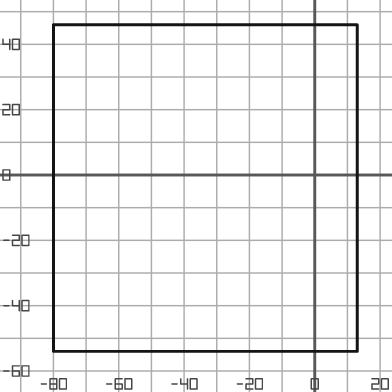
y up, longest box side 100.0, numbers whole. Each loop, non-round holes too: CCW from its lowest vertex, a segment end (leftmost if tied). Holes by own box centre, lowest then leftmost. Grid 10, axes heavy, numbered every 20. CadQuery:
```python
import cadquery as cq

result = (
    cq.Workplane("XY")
    .moveTo(-80.0, -54.0)
    .lineTo(13.0, -54.0)
    .lineTo(13.0, 46.0)
    .lineTo(-80.0, 46.0)
    .close()
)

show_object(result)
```